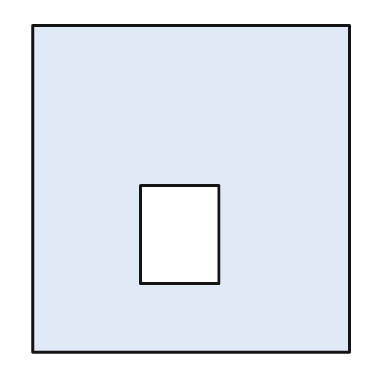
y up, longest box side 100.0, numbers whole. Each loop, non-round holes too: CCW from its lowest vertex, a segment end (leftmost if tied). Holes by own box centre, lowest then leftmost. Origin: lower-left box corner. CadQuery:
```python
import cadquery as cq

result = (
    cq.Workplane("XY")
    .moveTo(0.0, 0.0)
    .lineTo(97.0, 0.0)
    .lineTo(97.0, 100.0)
    .lineTo(0.0, 100.0)
    .close()
    .moveTo(33.0, 21.0)
    .lineTo(57.0, 21.0)
    .lineTo(57.0, 51.0)
    .lineTo(33.0, 51.0)
    .close()
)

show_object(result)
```